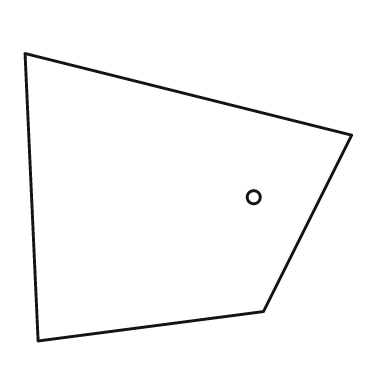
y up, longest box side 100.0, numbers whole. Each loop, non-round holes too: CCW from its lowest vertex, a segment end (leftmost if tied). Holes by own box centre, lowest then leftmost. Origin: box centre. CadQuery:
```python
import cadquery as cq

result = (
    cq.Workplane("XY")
    .moveTo(-46.0, -44.0)
    .lineTo(23.0, -35.0)
    .lineTo(50.0, 19.0)
    .lineTo(-50.0, 44.0)
    .close()
    .moveTo(20.0, 0.0)
    .circle(2.0)
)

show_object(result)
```